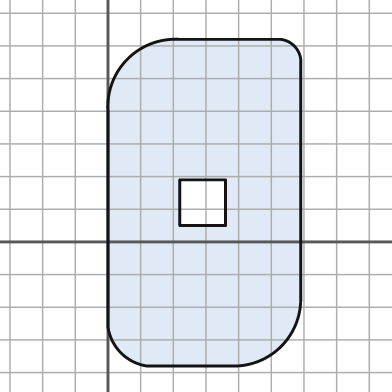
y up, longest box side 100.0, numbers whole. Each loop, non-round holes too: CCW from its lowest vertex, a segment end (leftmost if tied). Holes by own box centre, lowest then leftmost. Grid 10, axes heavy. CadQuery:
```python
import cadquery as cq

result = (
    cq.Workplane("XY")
    .moveTo(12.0, -38.0)
    .lineTo(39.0, -38.0)
    .threePointArc((53.0, -32.0), (59.0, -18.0))
    .lineTo(59.0, 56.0)
    .threePointArc((57.0, 60.0), (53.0, 62.0))
    .lineTo(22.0, 62.0)
    .threePointArc((6.0, 56.0), (0.0, 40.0))
    .lineTo(0.0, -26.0)
    .threePointArc((4.0, -34.0), (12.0, -38.0))
    .close()
    .moveTo(22.0, 5.0)
    .lineTo(36.0, 5.0)
    .lineTo(36.0, 19.0)
    .lineTo(22.0, 19.0)
    .close()
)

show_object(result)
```